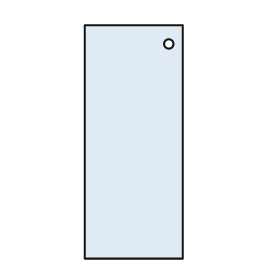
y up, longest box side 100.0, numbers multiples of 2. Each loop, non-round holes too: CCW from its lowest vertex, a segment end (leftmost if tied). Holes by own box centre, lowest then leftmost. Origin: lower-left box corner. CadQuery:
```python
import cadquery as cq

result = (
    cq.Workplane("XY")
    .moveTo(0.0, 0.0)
    .lineTo(42.0, 0.0)
    .lineTo(42.0, 100.0)
    .lineTo(0.0, 100.0)
    .close()
    .moveTo(36.0, 92.0)
    .circle(2.0)
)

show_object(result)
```